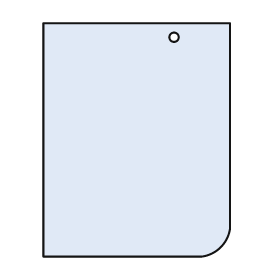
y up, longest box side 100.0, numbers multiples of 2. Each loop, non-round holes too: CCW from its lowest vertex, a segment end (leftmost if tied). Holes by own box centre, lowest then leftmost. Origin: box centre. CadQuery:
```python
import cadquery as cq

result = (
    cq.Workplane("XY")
    .moveTo(-40.0, -50.0)
    .lineTo(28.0, -50.0)
    .threePointArc((36.0, -46.0), (40.0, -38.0))
    .lineTo(40.0, 50.0)
    .lineTo(-40.0, 50.0)
    .close()
    .moveTo(16.0, 44.0)
    .circle(2.0)
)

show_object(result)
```